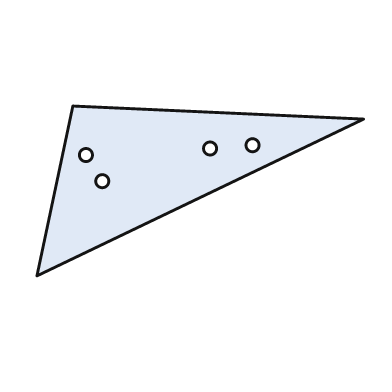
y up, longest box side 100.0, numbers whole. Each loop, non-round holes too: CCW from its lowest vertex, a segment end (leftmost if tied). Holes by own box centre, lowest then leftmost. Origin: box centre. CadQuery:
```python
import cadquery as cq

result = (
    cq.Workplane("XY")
    .moveTo(-50.0, -26.0)
    .lineTo(50.0, 22.0)
    .lineTo(-39.0, 26.0)
    .close()
    .moveTo(-30.0, 3.0)
    .circle(2.0)
    .moveTo(-35.0, 11.0)
    .circle(2.0)
    .moveTo(3.0, 13.0)
    .circle(2.0)
    .moveTo(16.0, 14.0)
    .circle(2.0)
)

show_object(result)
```